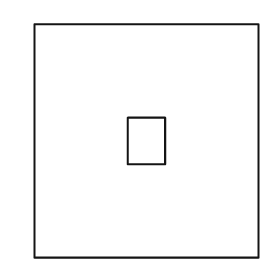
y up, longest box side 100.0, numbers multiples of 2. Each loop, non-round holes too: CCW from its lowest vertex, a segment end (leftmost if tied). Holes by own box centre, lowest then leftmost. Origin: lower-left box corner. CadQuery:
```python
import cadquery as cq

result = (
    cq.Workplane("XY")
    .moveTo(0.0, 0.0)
    .lineTo(96.0, 0.0)
    .lineTo(96.0, 100.0)
    .lineTo(0.0, 100.0)
    .close()
    .moveTo(40.0, 40.0)
    .lineTo(56.0, 40.0)
    .lineTo(56.0, 60.0)
    .lineTo(40.0, 60.0)
    .close()
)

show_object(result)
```